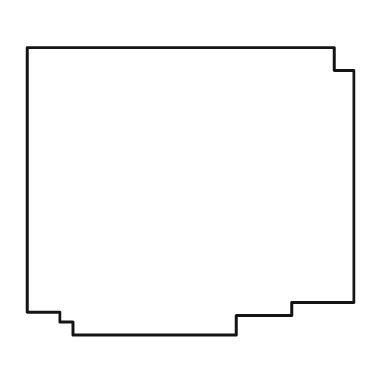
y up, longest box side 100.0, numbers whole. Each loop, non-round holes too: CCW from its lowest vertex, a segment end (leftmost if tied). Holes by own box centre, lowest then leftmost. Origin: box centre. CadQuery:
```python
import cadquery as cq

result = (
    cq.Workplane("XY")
    .moveTo(-36.0, -44.0)
    .lineTo(14.0, -44.0)
    .lineTo(14.0, -38.0)
    .lineTo(31.0, -38.0)
    .lineTo(31.0, -34.0)
    .lineTo(50.0, -34.0)
    .lineTo(50.0, 37.0)
    .lineTo(44.0, 37.0)
    .lineTo(44.0, 44.0)
    .lineTo(-50.0, 44.0)
    .lineTo(-50.0, -37.0)
    .lineTo(-40.0, -37.0)
    .lineTo(-40.0, -40.0)
    .lineTo(-36.0, -40.0)
    .close()
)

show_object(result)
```